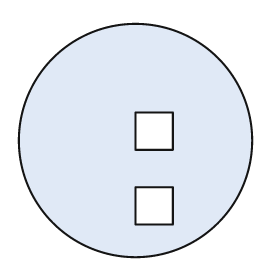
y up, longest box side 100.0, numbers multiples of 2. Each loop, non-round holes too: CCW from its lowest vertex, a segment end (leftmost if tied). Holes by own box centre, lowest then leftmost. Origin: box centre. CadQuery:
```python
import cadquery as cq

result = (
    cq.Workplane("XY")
    .moveTo(0.0, 0.0)
    .circle(50.0)
    .moveTo(0.0, -36.0)
    .lineTo(16.0, -36.0)
    .lineTo(16.0, -20.0)
    .lineTo(0.0, -20.0)
    .close()
    .moveTo(0.0, -4.0)
    .lineTo(16.0, -4.0)
    .lineTo(16.0, 12.0)
    .lineTo(0.0, 12.0)
    .close()
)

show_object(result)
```